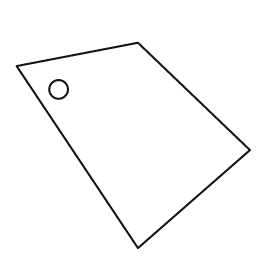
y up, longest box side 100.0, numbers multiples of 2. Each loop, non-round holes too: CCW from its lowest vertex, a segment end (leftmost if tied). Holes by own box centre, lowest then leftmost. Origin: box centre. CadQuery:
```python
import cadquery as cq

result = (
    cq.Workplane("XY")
    .moveTo(2.0, -44.0)
    .lineTo(50.0, -2.0)
    .lineTo(2.0, 44.0)
    .lineTo(-50.0, 34.0)
    .close()
    .moveTo(-32.0, 24.0)
    .circle(4.0)
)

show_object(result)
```